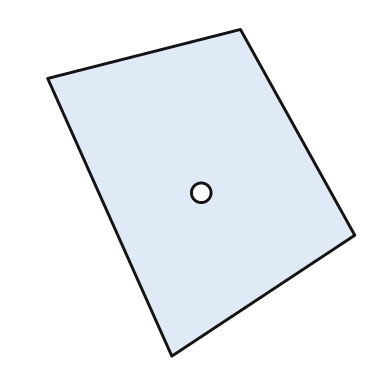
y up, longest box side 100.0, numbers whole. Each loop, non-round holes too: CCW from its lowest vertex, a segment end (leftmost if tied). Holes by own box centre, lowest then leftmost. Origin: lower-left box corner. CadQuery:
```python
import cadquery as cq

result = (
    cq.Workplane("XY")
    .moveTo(38.0, 0.0)
    .lineTo(94.0, 37.0)
    .lineTo(59.0, 100.0)
    .lineTo(0.0, 85.0)
    .close()
    .moveTo(47.0, 50.0)
    .circle(3.0)
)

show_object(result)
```